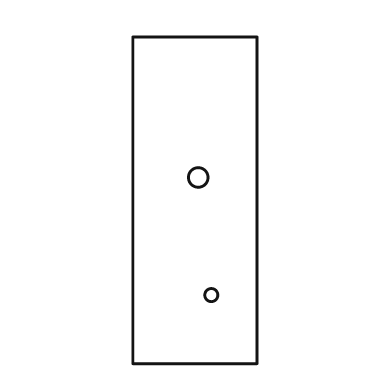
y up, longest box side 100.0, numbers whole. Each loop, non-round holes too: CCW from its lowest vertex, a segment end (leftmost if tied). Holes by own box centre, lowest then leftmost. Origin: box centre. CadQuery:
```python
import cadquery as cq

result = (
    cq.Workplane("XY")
    .moveTo(-19.0, -50.0)
    .lineTo(19.0, -50.0)
    .lineTo(19.0, 50.0)
    .lineTo(-19.0, 50.0)
    .close()
    .moveTo(5.0, -29.0)
    .circle(2.0)
    .moveTo(1.0, 7.0)
    .circle(3.0)
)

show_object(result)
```